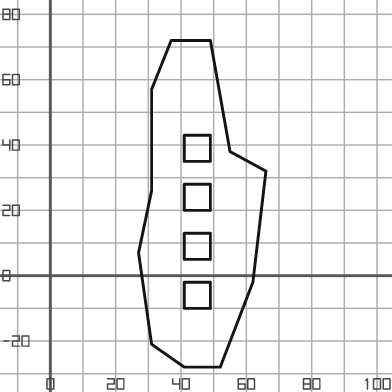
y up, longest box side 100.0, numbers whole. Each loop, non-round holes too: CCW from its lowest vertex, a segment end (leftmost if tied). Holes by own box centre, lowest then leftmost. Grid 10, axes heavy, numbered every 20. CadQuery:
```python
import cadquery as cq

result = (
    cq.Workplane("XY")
    .moveTo(41.0, -28.0)
    .lineTo(52.0, -28.0)
    .lineTo(62.0, -2.0)
    .lineTo(66.0, 32.0)
    .lineTo(55.0, 38.0)
    .lineTo(49.0, 72.0)
    .lineTo(37.0, 72.0)
    .lineTo(31.0, 57.0)
    .lineTo(31.0, 26.0)
    .lineTo(27.0, 7.0)
    .lineTo(31.0, -21.0)
    .close()
    .moveTo(41.0, -10.0)
    .lineTo(49.0, -10.0)
    .lineTo(49.0, -2.0)
    .lineTo(41.0, -2.0)
    .close()
    .moveTo(41.0, 5.0)
    .lineTo(49.0, 5.0)
    .lineTo(49.0, 13.0)
    .lineTo(41.0, 13.0)
    .close()
    .moveTo(41.0, 20.0)
    .lineTo(49.0, 20.0)
    .lineTo(49.0, 28.0)
    .lineTo(41.0, 28.0)
    .close()
    .moveTo(41.0, 35.0)
    .lineTo(49.0, 35.0)
    .lineTo(49.0, 43.0)
    .lineTo(41.0, 43.0)
    .close()
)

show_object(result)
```